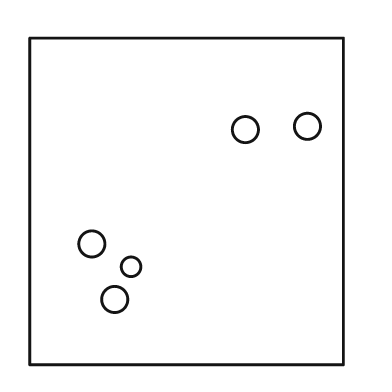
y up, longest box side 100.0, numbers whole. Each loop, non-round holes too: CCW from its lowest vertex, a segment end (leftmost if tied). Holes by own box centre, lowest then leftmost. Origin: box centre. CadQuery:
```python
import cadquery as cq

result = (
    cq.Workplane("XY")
    .moveTo(-48.0, -50.0)
    .lineTo(48.0, -50.0)
    .lineTo(48.0, 50.0)
    .lineTo(-48.0, 50.0)
    .close()
    .moveTo(-22.0, -30.0)
    .circle(4.0)
    .moveTo(-17.0, -20.0)
    .circle(3.0)
    .moveTo(-29.0, -13.0)
    .circle(4.0)
    .moveTo(18.0, 22.0)
    .circle(4.0)
    .moveTo(37.0, 23.0)
    .circle(4.0)
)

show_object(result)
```